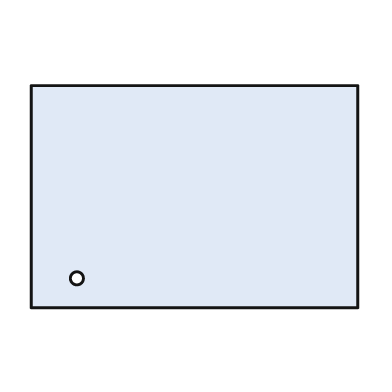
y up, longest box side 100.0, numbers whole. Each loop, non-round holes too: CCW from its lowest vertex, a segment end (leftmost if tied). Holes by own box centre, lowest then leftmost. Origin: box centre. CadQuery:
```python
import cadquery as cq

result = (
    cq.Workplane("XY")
    .moveTo(-50.0, -34.0)
    .lineTo(50.0, -34.0)
    .lineTo(50.0, 34.0)
    .lineTo(-50.0, 34.0)
    .close()
    .moveTo(-36.0, -25.0)
    .circle(2.0)
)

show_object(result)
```